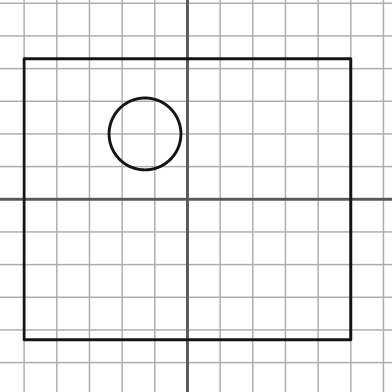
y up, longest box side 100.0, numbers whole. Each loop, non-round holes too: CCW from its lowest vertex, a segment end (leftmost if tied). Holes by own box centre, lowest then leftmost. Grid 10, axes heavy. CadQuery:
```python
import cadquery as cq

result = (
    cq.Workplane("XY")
    .moveTo(-50.0, -43.0)
    .lineTo(50.0, -43.0)
    .lineTo(50.0, 43.0)
    .lineTo(-50.0, 43.0)
    .close()
    .moveTo(-13.0, 20.0)
    .circle(11.0)
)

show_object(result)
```